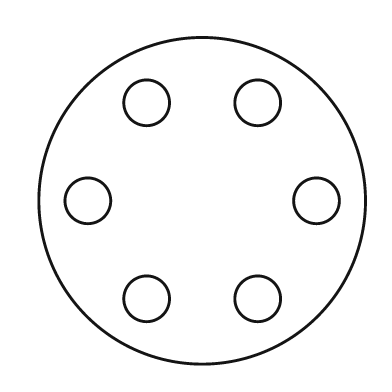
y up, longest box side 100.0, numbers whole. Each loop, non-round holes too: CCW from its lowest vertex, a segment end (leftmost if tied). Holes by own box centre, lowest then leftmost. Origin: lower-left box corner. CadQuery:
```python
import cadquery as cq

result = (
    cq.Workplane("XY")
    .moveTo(50.0, 50.0)
    .circle(50.0)
    .moveTo(33.0, 20.0)
    .circle(7.0)
    .moveTo(67.0, 20.0)
    .circle(7.0)
    .moveTo(15.0, 50.0)
    .circle(7.0)
    .moveTo(85.0, 50.0)
    .circle(7.0)
    .moveTo(33.0, 80.0)
    .circle(7.0)
    .moveTo(67.0, 80.0)
    .circle(7.0)
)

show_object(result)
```